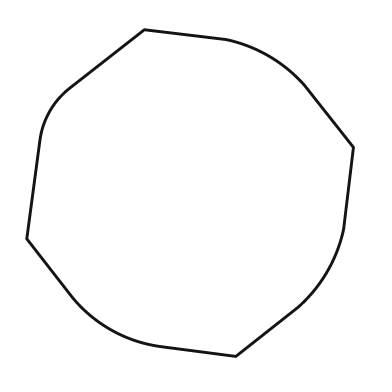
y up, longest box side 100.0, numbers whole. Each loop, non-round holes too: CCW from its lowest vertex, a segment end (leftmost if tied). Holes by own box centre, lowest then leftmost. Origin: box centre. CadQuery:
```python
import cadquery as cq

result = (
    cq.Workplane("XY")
    .moveTo(14.0, -50.0)
    .lineTo(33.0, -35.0)
    .threePointArc((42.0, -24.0), (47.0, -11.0))
    .lineTo(50.0, 14.0)
    .lineTo(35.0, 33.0)
    .threePointArc((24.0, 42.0), (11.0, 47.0))
    .lineTo(-14.0, 50.0)
    .lineTo(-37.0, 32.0)
    .threePointArc((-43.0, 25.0), (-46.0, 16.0))
    .lineTo(-50.0, -14.0)
    .lineTo(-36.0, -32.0)
    .threePointArc((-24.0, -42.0), (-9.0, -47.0))
    .close()
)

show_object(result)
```